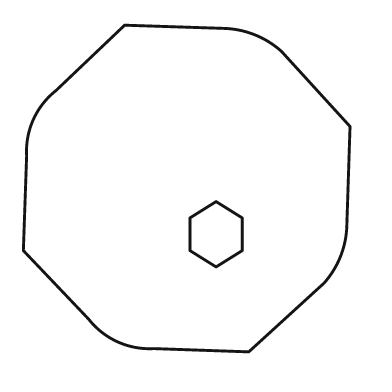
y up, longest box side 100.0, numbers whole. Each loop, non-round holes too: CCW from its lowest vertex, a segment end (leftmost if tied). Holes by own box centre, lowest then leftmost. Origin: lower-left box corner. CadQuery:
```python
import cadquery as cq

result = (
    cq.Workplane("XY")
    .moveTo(69.0, 0.0)
    .lineTo(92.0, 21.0)
    .threePointArc((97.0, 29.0), (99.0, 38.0))
    .lineTo(100.0, 69.0)
    .lineTo(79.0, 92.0)
    .threePointArc((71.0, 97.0), (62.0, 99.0))
    .lineTo(31.0, 100.0)
    .lineTo(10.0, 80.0)
    .threePointArc((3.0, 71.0), (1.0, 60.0))
    .lineTo(0.0, 31.0)
    .lineTo(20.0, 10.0)
    .threePointArc((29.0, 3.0), (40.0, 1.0))
    .close()
    .moveTo(59.0, 26.0)
    .lineTo(67.0, 31.0)
    .lineTo(67.0, 41.0)
    .lineTo(59.0, 46.0)
    .lineTo(51.0, 41.0)
    .lineTo(51.0, 31.0)
    .close()
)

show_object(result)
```